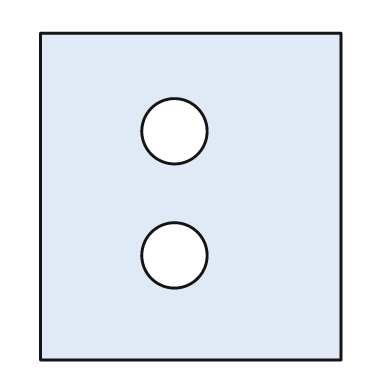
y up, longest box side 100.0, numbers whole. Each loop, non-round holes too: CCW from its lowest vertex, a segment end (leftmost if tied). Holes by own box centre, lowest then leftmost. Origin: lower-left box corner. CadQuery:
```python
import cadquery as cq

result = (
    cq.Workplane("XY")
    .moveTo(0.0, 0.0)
    .lineTo(92.0, 0.0)
    .lineTo(92.0, 100.0)
    .lineTo(0.0, 100.0)
    .close()
    .moveTo(41.0, 32.0)
    .circle(10.0)
    .moveTo(41.0, 70.0)
    .circle(10.0)
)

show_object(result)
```